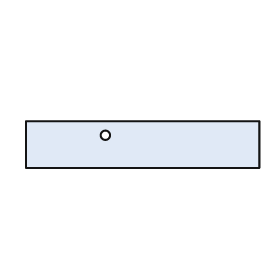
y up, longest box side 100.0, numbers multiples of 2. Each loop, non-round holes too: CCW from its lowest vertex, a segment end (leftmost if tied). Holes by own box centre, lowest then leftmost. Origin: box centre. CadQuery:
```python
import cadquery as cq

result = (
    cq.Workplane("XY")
    .moveTo(-50.0, -10.0)
    .lineTo(50.0, -10.0)
    .lineTo(50.0, 10.0)
    .lineTo(-50.0, 10.0)
    .close()
    .moveTo(-16.0, 4.0)
    .circle(2.0)
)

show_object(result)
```